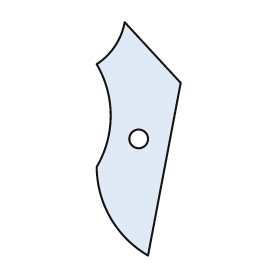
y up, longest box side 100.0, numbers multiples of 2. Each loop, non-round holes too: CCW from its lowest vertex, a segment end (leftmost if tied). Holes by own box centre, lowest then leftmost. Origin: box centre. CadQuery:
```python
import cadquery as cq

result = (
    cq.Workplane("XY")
    .moveTo(4.0, -50.0)
    .lineTo(18.0, 24.0)
    .lineTo(-6.0, 50.0)
    .threePointArc((-10.0, 40.0), (-18.0, 32.0))
    .threePointArc((-12.0, 10.0), (-18.0, -12.0))
    .threePointArc((-12.0, -34.0), (4.0, -50.0))
    .close()
    .moveTo(0.0, 0.0)
    .circle(4.0)
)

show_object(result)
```